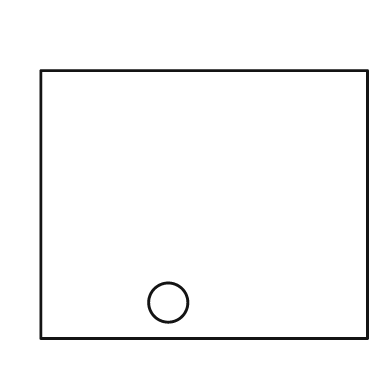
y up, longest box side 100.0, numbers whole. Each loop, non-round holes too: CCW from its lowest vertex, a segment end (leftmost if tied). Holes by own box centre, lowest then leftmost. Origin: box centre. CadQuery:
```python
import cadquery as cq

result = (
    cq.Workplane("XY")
    .moveTo(-50.0, -41.0)
    .lineTo(50.0, -41.0)
    .lineTo(50.0, 41.0)
    .lineTo(-50.0, 41.0)
    .close()
    .moveTo(-11.0, -30.0)
    .circle(6.0)
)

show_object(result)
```